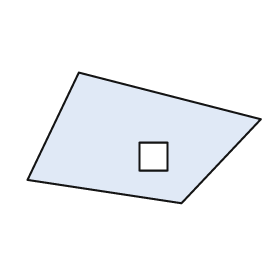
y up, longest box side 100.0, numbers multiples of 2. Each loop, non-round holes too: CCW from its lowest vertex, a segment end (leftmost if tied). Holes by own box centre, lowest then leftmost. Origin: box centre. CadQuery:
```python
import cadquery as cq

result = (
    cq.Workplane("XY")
    .moveTo(16.0, -28.0)
    .lineTo(50.0, 8.0)
    .lineTo(-28.0, 28.0)
    .lineTo(-50.0, -18.0)
    .close()
    .moveTo(-2.0, -14.0)
    .lineTo(10.0, -14.0)
    .lineTo(10.0, -2.0)
    .lineTo(-2.0, -2.0)
    .close()
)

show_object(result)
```